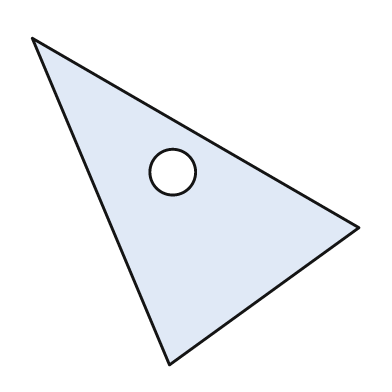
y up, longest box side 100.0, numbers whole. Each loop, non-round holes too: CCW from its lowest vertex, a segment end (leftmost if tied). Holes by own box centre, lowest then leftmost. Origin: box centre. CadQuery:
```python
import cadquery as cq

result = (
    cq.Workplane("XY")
    .moveTo(-8.0, -50.0)
    .lineTo(50.0, -8.0)
    .lineTo(-50.0, 50.0)
    .close()
    .moveTo(-7.0, 9.0)
    .circle(7.0)
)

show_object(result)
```